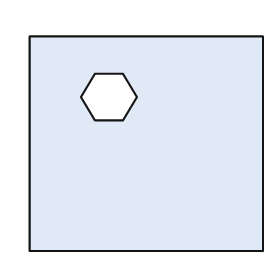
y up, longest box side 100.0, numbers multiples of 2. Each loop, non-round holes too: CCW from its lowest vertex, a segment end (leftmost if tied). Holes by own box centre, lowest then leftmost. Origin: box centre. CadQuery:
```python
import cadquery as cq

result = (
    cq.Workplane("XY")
    .moveTo(-50.0, -46.0)
    .lineTo(50.0, -46.0)
    .lineTo(50.0, 46.0)
    .lineTo(-50.0, 46.0)
    .close()
    .moveTo(-22.0, 10.0)
    .lineTo(-10.0, 10.0)
    .lineTo(-4.0, 20.0)
    .lineTo(-10.0, 30.0)
    .lineTo(-22.0, 30.0)
    .lineTo(-28.0, 20.0)
    .close()
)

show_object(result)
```